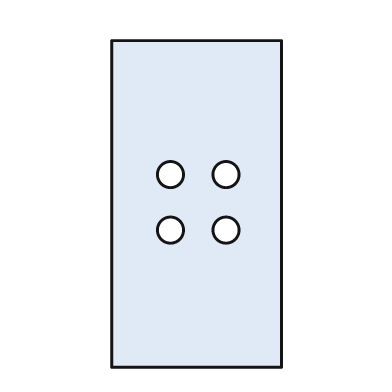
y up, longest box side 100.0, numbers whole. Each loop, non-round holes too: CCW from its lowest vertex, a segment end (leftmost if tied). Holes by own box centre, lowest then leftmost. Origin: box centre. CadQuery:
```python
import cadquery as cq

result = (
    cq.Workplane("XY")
    .moveTo(-26.0, -50.0)
    .lineTo(26.0, -50.0)
    .lineTo(26.0, 50.0)
    .lineTo(-26.0, 50.0)
    .close()
    .moveTo(-8.0, -8.0)
    .circle(4.0)
    .moveTo(9.0, -8.0)
    .circle(4.0)
    .moveTo(-8.0, 9.0)
    .circle(4.0)
    .moveTo(9.0, 9.0)
    .circle(4.0)
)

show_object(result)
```